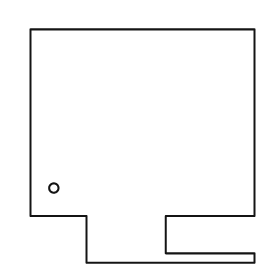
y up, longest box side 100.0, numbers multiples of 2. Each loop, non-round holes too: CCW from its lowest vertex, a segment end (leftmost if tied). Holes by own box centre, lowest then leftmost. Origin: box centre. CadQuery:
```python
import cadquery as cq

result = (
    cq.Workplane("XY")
    .moveTo(-24.0, -50.0)
    .lineTo(48.0, -50.0)
    .lineTo(48.0, -46.0)
    .lineTo(10.0, -46.0)
    .lineTo(10.0, -30.0)
    .lineTo(48.0, -30.0)
    .lineTo(48.0, 50.0)
    .lineTo(-48.0, 50.0)
    .lineTo(-48.0, -30.0)
    .lineTo(-24.0, -30.0)
    .close()
    .moveTo(-38.0, -18.0)
    .circle(2.0)
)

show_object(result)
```